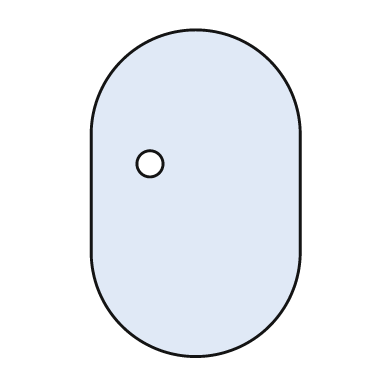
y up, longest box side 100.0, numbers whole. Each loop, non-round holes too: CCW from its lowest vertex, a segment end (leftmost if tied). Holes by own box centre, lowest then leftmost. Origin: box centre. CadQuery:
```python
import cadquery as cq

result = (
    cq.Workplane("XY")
    .moveTo(-32.0, -18.0)
    .threePointArc((0.0, -50.0), (32.0, -18.0))
    .lineTo(32.0, 18.0)
    .threePointArc((0.0, 50.0), (-32.0, 18.0))
    .close()
    .moveTo(-14.0, 9.0)
    .circle(4.0)
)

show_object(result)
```